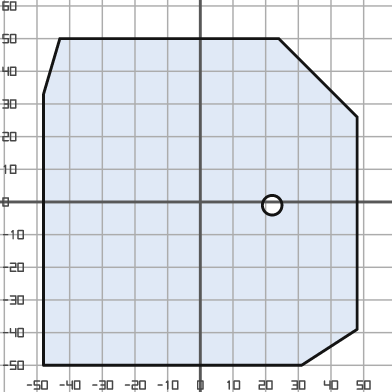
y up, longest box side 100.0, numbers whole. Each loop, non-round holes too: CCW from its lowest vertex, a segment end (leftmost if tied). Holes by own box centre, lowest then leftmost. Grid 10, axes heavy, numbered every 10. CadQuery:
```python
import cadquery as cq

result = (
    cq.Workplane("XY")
    .moveTo(-48.0, -50.0)
    .lineTo(31.0, -50.0)
    .lineTo(48.0, -39.0)
    .lineTo(48.0, 26.0)
    .lineTo(24.0, 50.0)
    .lineTo(-43.0, 50.0)
    .lineTo(-48.0, 33.0)
    .close()
    .moveTo(22.0, -1.0)
    .circle(3.0)
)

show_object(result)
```